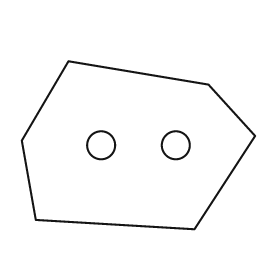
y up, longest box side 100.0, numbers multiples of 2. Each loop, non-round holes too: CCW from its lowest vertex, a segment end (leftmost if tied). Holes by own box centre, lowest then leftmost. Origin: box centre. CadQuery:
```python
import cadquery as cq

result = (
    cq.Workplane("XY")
    .moveTo(24.0, -36.0)
    .lineTo(50.0, 4.0)
    .lineTo(30.0, 26.0)
    .lineTo(-30.0, 36.0)
    .lineTo(-50.0, 2.0)
    .lineTo(-44.0, -32.0)
    .close()
    .moveTo(-16.0, 0.0)
    .circle(6.0)
    .moveTo(16.0, 0.0)
    .circle(6.0)
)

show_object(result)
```